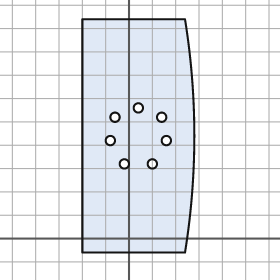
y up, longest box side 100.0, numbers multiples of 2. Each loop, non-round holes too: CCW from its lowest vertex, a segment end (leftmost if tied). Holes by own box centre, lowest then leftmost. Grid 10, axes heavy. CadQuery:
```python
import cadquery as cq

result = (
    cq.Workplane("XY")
    .moveTo(-20.0, -6.0)
    .lineTo(24.0, -6.0)
    .threePointArc((28.0, 44.0), (24.0, 94.0))
    .lineTo(-20.0, 94.0)
    .close()
    .moveTo(-2.0, 32.0)
    .circle(2.0)
    .moveTo(10.0, 32.0)
    .circle(2.0)
    .moveTo(-8.0, 42.0)
    .circle(2.0)
    .moveTo(16.0, 42.0)
    .circle(2.0)
    .moveTo(-6.0, 52.0)
    .circle(2.0)
    .moveTo(14.0, 52.0)
    .circle(2.0)
    .moveTo(4.0, 56.0)
    .circle(2.0)
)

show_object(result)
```